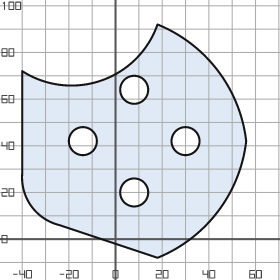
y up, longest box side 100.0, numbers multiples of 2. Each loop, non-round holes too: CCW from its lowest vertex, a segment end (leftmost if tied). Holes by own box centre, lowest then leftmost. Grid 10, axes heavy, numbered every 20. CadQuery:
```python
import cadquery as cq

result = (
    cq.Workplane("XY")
    .moveTo(18.0, -8.0)
    .threePointArc((44.0, 12.0), (56.0, 42.0))
    .threePointArc((44.0, 72.0), (18.0, 92.0))
    .threePointArc((-6.0, 68.0), (-40.0, 72.0))
    .lineTo(-40.0, 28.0)
    .threePointArc((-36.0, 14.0), (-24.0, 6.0))
    .close()
    .moveTo(8.0, 20.0)
    .circle(6.0)
    .moveTo(-14.0, 42.0)
    .circle(6.0)
    .moveTo(30.0, 42.0)
    .circle(6.0)
    .moveTo(8.0, 64.0)
    .circle(6.0)
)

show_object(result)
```